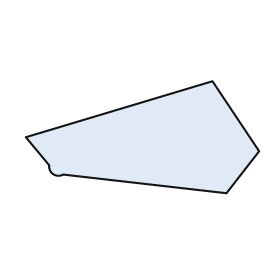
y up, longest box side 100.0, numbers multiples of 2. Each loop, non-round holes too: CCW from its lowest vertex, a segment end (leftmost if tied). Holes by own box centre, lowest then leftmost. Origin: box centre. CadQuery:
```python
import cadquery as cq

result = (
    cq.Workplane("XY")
    .moveTo(36.0, -24.0)
    .lineTo(50.0, -6.0)
    .lineTo(30.0, 24.0)
    .lineTo(-50.0, 0.0)
    .lineTo(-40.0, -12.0)
    .threePointArc((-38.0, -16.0), (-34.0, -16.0))
    .close()
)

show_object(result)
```